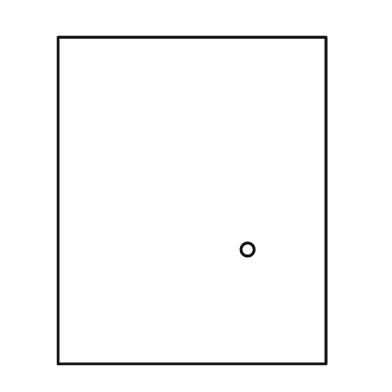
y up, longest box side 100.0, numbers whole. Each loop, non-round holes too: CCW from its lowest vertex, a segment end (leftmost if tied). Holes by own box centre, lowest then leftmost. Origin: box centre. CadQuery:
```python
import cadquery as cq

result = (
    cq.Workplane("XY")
    .moveTo(-41.0, -50.0)
    .lineTo(41.0, -50.0)
    .lineTo(41.0, 50.0)
    .lineTo(-41.0, 50.0)
    .close()
    .moveTo(17.0, -15.0)
    .circle(2.0)
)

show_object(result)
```